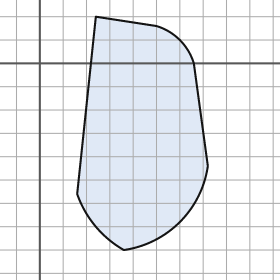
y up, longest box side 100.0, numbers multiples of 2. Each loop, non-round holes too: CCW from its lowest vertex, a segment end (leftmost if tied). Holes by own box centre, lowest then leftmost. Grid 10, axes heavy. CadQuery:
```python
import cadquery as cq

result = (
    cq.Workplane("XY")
    .moveTo(36.0, -80.0)
    .threePointArc((60.0, -68.0), (72.0, -44.0))
    .lineTo(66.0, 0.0)
    .threePointArc((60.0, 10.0), (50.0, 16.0))
    .lineTo(24.0, 20.0)
    .lineTo(16.0, -56.0)
    .threePointArc((24.0, -70.0), (36.0, -80.0))
    .close()
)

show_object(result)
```